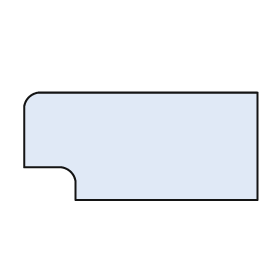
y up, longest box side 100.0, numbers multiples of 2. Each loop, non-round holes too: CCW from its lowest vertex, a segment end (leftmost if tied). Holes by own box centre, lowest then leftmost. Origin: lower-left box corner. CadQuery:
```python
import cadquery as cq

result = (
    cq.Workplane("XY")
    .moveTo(22.0, 0.0)
    .lineTo(100.0, 0.0)
    .lineTo(100.0, 46.0)
    .lineTo(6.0, 46.0)
    .threePointArc((2.0, 44.0), (0.0, 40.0))
    .lineTo(0.0, 14.0)
    .lineTo(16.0, 14.0)
    .threePointArc((20.0, 12.0), (22.0, 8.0))
    .close()
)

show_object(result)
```